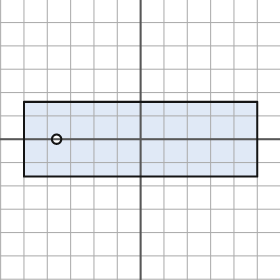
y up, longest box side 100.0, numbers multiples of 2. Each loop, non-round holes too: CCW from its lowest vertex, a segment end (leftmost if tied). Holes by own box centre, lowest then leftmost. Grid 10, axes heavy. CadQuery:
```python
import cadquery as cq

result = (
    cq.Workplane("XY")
    .moveTo(-50.0, -16.0)
    .lineTo(50.0, -16.0)
    .lineTo(50.0, 16.0)
    .lineTo(-50.0, 16.0)
    .close()
    .moveTo(-36.0, 0.0)
    .circle(2.0)
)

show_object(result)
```